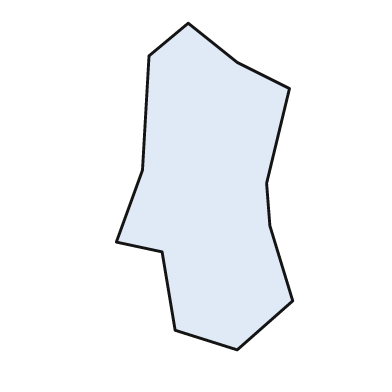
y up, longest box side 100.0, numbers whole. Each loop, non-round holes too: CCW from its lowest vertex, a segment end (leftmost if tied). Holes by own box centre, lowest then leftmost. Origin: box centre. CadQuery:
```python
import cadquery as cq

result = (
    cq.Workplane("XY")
    .moveTo(10.0, -50.0)
    .lineTo(27.0, -35.0)
    .lineTo(20.0, -12.0)
    .lineTo(19.0, 1.0)
    .lineTo(26.0, 30.0)
    .lineTo(10.0, 38.0)
    .lineTo(-5.0, 50.0)
    .lineTo(-17.0, 40.0)
    .lineTo(-19.0, 5.0)
    .lineTo(-27.0, -17.0)
    .lineTo(-13.0, -20.0)
    .lineTo(-9.0, -44.0)
    .close()
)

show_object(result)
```